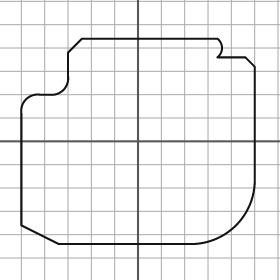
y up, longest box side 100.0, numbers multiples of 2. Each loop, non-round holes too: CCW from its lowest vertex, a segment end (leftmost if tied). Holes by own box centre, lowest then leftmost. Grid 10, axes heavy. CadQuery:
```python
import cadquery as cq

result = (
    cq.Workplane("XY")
    .moveTo(-34.0, -44.0)
    .lineTo(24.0, -44.0)
    .threePointArc((42.0, -36.0), (50.0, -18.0))
    .lineTo(50.0, 32.0)
    .lineTo(46.0, 36.0)
    .lineTo(34.0, 36.0)
    .threePointArc((36.0, 40.0), (34.0, 44.0))
    .lineTo(-24.0, 44.0)
    .lineTo(-30.0, 38.0)
    .lineTo(-30.0, 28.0)
    .threePointArc((-32.0, 22.0), (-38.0, 20.0))
    .lineTo(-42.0, 20.0)
    .threePointArc((-48.0, 18.0), (-50.0, 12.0))
    .lineTo(-50.0, -36.0)
    .close()
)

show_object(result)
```